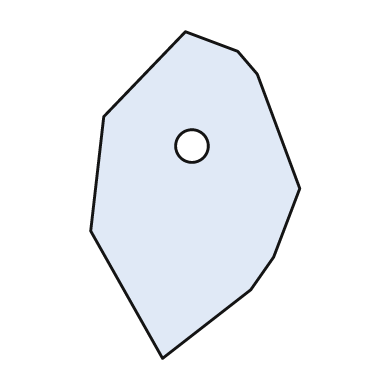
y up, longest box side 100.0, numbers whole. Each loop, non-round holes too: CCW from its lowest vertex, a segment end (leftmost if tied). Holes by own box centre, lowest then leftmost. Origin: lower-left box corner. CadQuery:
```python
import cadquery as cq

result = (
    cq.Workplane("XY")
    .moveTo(22.0, 0.0)
    .lineTo(49.0, 21.0)
    .lineTo(56.0, 31.0)
    .lineTo(64.0, 52.0)
    .lineTo(51.0, 87.0)
    .lineTo(45.0, 94.0)
    .lineTo(29.0, 100.0)
    .lineTo(4.0, 74.0)
    .lineTo(0.0, 39.0)
    .close()
    .moveTo(31.0, 65.0)
    .circle(5.0)
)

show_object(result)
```